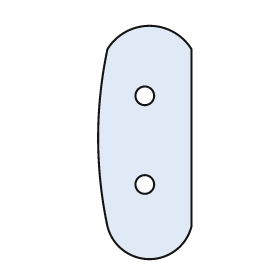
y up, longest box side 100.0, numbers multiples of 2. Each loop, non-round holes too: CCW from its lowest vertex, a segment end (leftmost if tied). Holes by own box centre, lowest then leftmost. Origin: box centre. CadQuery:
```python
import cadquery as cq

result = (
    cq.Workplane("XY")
    .moveTo(-16.0, -36.0)
    .threePointArc((2.0, -50.0), (20.0, -36.0))
    .lineTo(20.0, 40.0)
    .threePointArc((2.0, 50.0), (-16.0, 40.0))
    .threePointArc((-20.0, 2.0), (-16.0, -36.0))
    .close()
    .moveTo(0.0, -18.0)
    .circle(4.0)
    .moveTo(0.0, 20.0)
    .circle(4.0)
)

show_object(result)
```